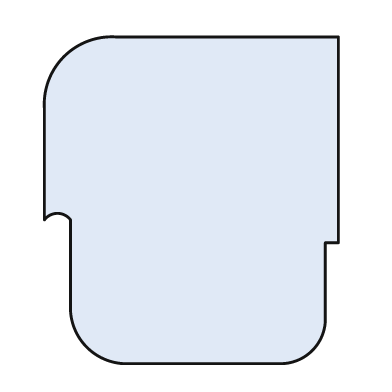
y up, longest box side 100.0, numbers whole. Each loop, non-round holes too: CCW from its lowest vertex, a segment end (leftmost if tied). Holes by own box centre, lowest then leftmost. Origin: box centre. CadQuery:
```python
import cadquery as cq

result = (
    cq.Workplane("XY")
    .moveTo(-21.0, -50.0)
    .lineTo(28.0, -50.0)
    .threePointArc((37.0, -46.0), (41.0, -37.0))
    .lineTo(41.0, -13.0)
    .lineTo(45.0, -13.0)
    .lineTo(45.0, 50.0)
    .lineTo(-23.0, 50.0)
    .threePointArc((-39.0, 44.0), (-45.0, 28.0))
    .lineTo(-45.0, -6.0)
    .threePointArc((-41.0, -4.0), (-37.0, -6.0))
    .lineTo(-37.0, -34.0)
    .threePointArc((-32.0, -45.0), (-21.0, -50.0))
    .close()
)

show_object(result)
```